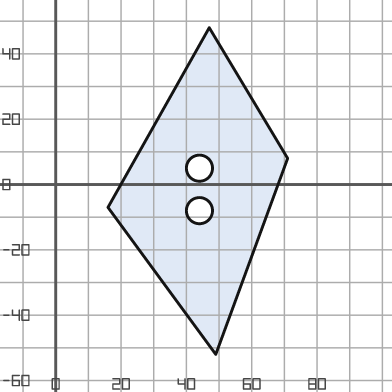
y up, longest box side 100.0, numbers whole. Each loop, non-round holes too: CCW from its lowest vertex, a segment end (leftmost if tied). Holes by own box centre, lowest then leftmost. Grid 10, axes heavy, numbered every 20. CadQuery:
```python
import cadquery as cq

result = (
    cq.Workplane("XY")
    .moveTo(49.0, -52.0)
    .lineTo(71.0, 8.0)
    .lineTo(47.0, 48.0)
    .lineTo(16.0, -7.0)
    .close()
    .moveTo(44.0, -8.0)
    .circle(4.0)
    .moveTo(44.0, 5.0)
    .circle(4.0)
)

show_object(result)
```